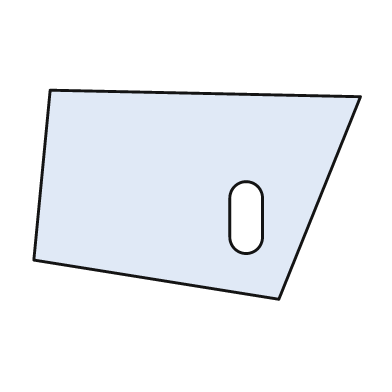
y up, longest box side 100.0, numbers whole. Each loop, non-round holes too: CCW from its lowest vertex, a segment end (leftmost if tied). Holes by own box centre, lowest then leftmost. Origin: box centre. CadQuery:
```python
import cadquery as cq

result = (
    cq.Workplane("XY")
    .moveTo(25.0, -32.0)
    .lineTo(50.0, 30.0)
    .lineTo(-45.0, 32.0)
    .lineTo(-50.0, -20.0)
    .close()
    .moveTo(10.0, -13.0)
    .threePointArc((15.0, -18.0), (20.0, -13.0))
    .lineTo(20.0, -1.0)
    .threePointArc((15.0, 4.0), (10.0, -1.0))
    .close()
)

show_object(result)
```